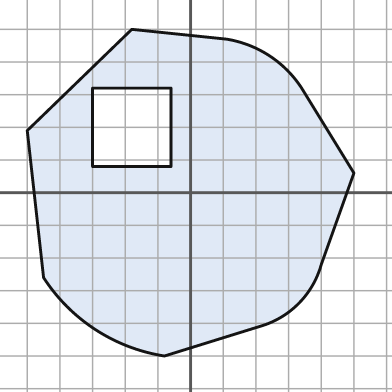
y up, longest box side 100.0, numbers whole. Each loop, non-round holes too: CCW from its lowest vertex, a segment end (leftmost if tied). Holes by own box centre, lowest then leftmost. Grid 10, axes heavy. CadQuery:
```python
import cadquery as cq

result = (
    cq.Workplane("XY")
    .moveTo(-8.0, -50.0)
    .lineTo(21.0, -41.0)
    .threePointArc((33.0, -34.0), (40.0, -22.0))
    .lineTo(50.0, 6.0)
    .lineTo(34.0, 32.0)
    .threePointArc((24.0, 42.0), (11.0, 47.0))
    .lineTo(-18.0, 50.0)
    .lineTo(-50.0, 19.0)
    .lineTo(-45.0, -26.0)
    .threePointArc((-29.0, -42.0), (-8.0, -50.0))
    .close()
    .moveTo(-30.0, 8.0)
    .lineTo(-6.0, 8.0)
    .lineTo(-6.0, 32.0)
    .lineTo(-30.0, 32.0)
    .close()
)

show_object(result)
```